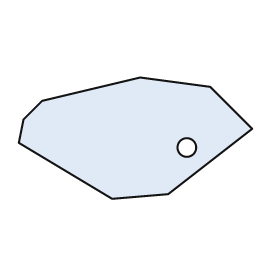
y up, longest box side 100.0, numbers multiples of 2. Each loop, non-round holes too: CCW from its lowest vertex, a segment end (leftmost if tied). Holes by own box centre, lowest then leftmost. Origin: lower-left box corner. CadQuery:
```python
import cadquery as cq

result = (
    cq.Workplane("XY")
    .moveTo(40.0, 0.0)
    .lineTo(64.0, 2.0)
    .lineTo(100.0, 30.0)
    .lineTo(82.0, 48.0)
    .lineTo(52.0, 52.0)
    .lineTo(10.0, 42.0)
    .lineTo(2.0, 34.0)
    .lineTo(0.0, 24.0)
    .close()
    .moveTo(72.0, 22.0)
    .circle(4.0)
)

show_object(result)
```